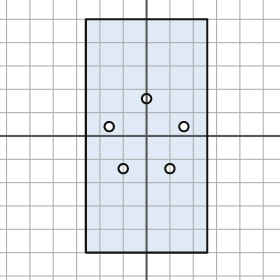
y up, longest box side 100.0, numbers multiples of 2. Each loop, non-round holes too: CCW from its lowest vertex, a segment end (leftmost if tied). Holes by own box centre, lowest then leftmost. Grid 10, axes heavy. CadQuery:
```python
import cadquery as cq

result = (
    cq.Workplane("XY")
    .moveTo(-26.0, -50.0)
    .lineTo(26.0, -50.0)
    .lineTo(26.0, 50.0)
    .lineTo(-26.0, 50.0)
    .close()
    .moveTo(-10.0, -14.0)
    .circle(2.0)
    .moveTo(10.0, -14.0)
    .circle(2.0)
    .moveTo(-16.0, 4.0)
    .circle(2.0)
    .moveTo(16.0, 4.0)
    .circle(2.0)
    .moveTo(0.0, 16.0)
    .circle(2.0)
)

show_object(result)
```